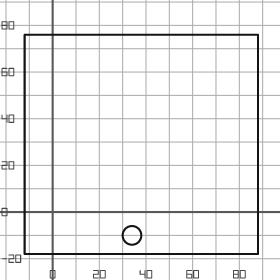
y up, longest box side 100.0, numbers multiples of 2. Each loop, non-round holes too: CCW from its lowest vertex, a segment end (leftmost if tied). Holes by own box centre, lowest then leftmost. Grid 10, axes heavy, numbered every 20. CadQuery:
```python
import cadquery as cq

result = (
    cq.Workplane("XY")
    .moveTo(-12.0, -18.0)
    .lineTo(88.0, -18.0)
    .lineTo(88.0, 76.0)
    .lineTo(-12.0, 76.0)
    .close()
    .moveTo(34.0, -10.0)
    .circle(4.0)
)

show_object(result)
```